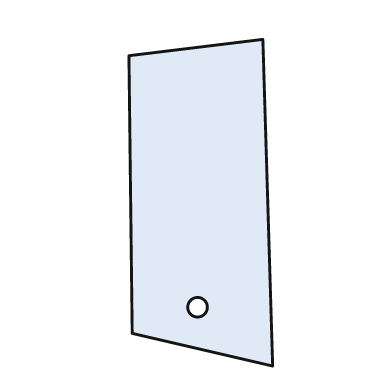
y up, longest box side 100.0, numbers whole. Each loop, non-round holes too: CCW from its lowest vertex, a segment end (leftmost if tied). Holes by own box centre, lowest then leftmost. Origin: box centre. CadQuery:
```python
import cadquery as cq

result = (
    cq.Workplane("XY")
    .moveTo(22.0, -50.0)
    .lineTo(19.0, 50.0)
    .lineTo(-22.0, 45.0)
    .lineTo(-21.0, -40.0)
    .close()
    .moveTo(-1.0, -32.0)
    .circle(3.0)
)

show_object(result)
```